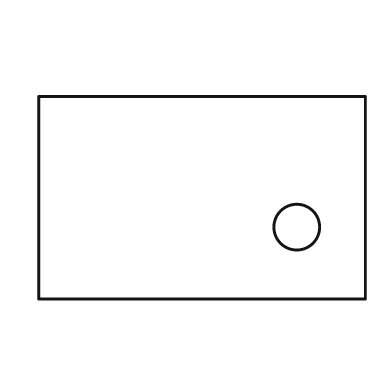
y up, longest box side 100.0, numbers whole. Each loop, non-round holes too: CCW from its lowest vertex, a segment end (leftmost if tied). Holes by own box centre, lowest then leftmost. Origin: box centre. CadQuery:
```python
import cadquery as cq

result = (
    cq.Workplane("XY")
    .moveTo(-50.0, -31.0)
    .lineTo(50.0, -31.0)
    .lineTo(50.0, 31.0)
    .lineTo(-50.0, 31.0)
    .close()
    .moveTo(29.0, -9.0)
    .circle(7.0)
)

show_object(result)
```